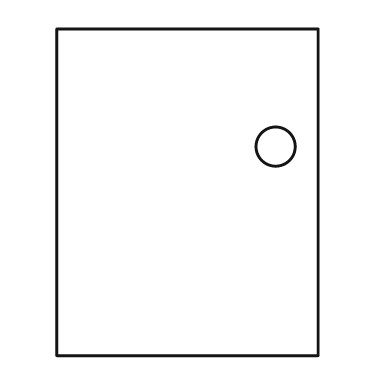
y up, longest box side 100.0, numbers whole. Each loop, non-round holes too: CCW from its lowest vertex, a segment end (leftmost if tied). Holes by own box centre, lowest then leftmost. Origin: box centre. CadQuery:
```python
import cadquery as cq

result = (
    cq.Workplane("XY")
    .moveTo(-40.0, -50.0)
    .lineTo(40.0, -50.0)
    .lineTo(40.0, 50.0)
    .lineTo(-40.0, 50.0)
    .close()
    .moveTo(27.0, 14.0)
    .circle(6.0)
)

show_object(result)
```